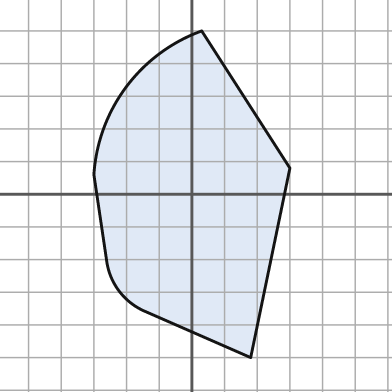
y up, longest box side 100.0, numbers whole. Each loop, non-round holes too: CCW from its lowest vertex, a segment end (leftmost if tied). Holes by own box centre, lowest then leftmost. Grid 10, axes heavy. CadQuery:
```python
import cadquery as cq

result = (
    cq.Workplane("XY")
    .moveTo(18.0, -50.0)
    .lineTo(30.0, 8.0)
    .lineTo(3.0, 50.0)
    .threePointArc((-20.0, 33.0), (-30.0, 6.0))
    .lineTo(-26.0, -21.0)
    .threePointArc((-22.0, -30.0), (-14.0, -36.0))
    .close()
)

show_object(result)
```